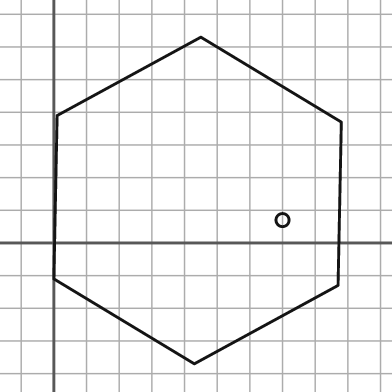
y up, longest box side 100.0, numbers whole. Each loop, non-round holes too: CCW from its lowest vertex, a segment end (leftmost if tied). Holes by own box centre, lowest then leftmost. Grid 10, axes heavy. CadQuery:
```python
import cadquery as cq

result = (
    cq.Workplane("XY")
    .moveTo(43.0, -37.0)
    .lineTo(87.0, -13.0)
    .lineTo(88.0, 37.0)
    .lineTo(45.0, 63.0)
    .lineTo(1.0, 39.0)
    .lineTo(0.0, -11.0)
    .close()
    .moveTo(70.0, 7.0)
    .circle(2.0)
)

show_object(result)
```